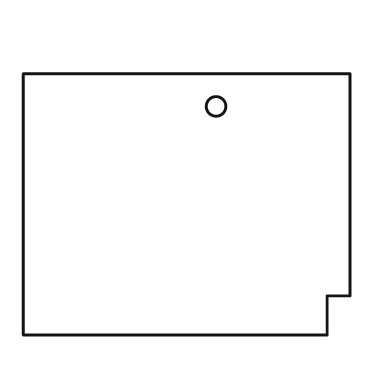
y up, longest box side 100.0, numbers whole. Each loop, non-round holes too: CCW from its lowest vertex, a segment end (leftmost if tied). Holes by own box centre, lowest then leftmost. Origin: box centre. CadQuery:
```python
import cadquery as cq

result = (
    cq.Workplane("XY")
    .moveTo(-50.0, -40.0)
    .lineTo(43.0, -40.0)
    .lineTo(43.0, -28.0)
    .lineTo(50.0, -28.0)
    .lineTo(50.0, 40.0)
    .lineTo(-50.0, 40.0)
    .close()
    .moveTo(9.0, 30.0)
    .circle(3.0)
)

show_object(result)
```